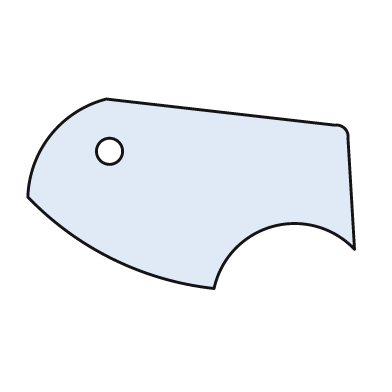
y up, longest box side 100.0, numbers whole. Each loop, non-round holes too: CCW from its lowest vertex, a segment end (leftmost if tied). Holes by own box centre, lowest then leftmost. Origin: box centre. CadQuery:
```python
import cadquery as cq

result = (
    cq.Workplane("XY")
    .moveTo(7.0, -29.0)
    .threePointArc((25.0, -10.0), (50.0, -17.0))
    .lineTo(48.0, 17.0)
    .threePointArc((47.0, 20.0), (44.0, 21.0))
    .lineTo(-26.0, 29.0)
    .threePointArc((-43.0, 18.0), (-50.0, -1.0))
    .threePointArc((-24.0, -20.0), (7.0, -29.0))
    .close()
    .moveTo(-25.0, 13.0)
    .circle(4.0)
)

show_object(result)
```